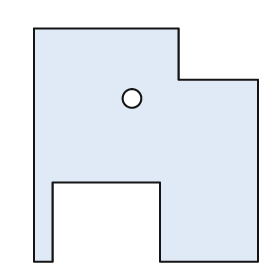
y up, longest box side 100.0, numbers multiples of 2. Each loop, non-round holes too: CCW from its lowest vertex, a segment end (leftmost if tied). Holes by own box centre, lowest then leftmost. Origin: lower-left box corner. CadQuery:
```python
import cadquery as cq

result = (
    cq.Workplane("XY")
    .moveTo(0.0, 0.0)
    .lineTo(8.0, 0.0)
    .lineTo(8.0, 34.0)
    .lineTo(54.0, 34.0)
    .lineTo(54.0, 0.0)
    .lineTo(96.0, 0.0)
    .lineTo(96.0, 78.0)
    .lineTo(62.0, 78.0)
    .lineTo(62.0, 100.0)
    .lineTo(0.0, 100.0)
    .close()
    .moveTo(42.0, 70.0)
    .circle(4.0)
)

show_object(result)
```